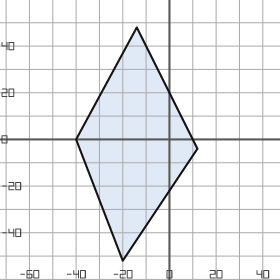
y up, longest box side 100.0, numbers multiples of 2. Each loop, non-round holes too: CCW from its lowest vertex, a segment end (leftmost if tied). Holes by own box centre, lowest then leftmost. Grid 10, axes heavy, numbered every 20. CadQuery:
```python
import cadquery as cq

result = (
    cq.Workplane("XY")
    .moveTo(-20.0, -52.0)
    .lineTo(12.0, -4.0)
    .lineTo(-14.0, 48.0)
    .lineTo(-40.0, 0.0)
    .close()
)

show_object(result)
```